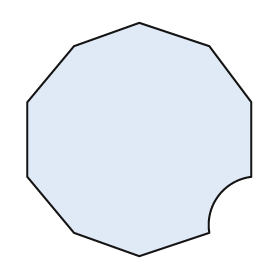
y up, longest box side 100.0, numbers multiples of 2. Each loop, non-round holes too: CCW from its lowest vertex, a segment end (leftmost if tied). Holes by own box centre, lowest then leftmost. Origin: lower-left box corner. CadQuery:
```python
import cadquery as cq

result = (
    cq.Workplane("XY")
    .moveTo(48.0, 0.0)
    .lineTo(78.0, 10.0)
    .threePointArc((82.0, 26.0), (96.0, 34.0))
    .lineTo(96.0, 66.0)
    .lineTo(78.0, 90.0)
    .lineTo(48.0, 100.0)
    .lineTo(20.0, 90.0)
    .lineTo(0.0, 66.0)
    .lineTo(0.0, 34.0)
    .lineTo(20.0, 10.0)
    .close()
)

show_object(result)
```